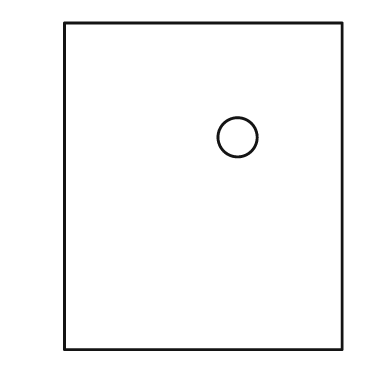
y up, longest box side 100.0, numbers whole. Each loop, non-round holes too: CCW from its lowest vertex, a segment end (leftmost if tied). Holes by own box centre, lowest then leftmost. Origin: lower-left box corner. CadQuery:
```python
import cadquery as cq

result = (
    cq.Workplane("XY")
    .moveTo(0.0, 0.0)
    .lineTo(85.0, 0.0)
    .lineTo(85.0, 100.0)
    .lineTo(0.0, 100.0)
    .close()
    .moveTo(53.0, 65.0)
    .circle(6.0)
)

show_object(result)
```